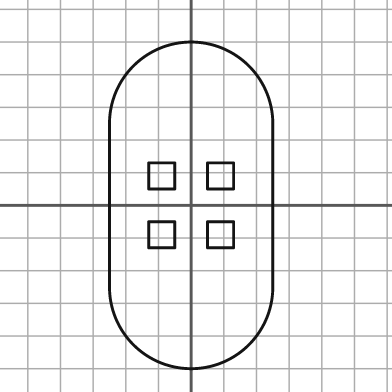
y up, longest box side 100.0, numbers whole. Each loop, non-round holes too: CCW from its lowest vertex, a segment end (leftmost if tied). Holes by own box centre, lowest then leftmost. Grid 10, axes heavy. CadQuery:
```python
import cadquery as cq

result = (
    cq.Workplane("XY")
    .moveTo(-25.0, -25.0)
    .threePointArc((0.0, -50.0), (25.0, -25.0))
    .lineTo(25.0, 25.0)
    .threePointArc((0.0, 50.0), (-25.0, 25.0))
    .close()
    .moveTo(-13.0, -13.0)
    .lineTo(-5.0, -13.0)
    .lineTo(-5.0, -5.0)
    .lineTo(-13.0, -5.0)
    .close()
    .moveTo(5.0, -13.0)
    .lineTo(13.0, -13.0)
    .lineTo(13.0, -5.0)
    .lineTo(5.0, -5.0)
    .close()
    .moveTo(-13.0, 5.0)
    .lineTo(-5.0, 5.0)
    .lineTo(-5.0, 13.0)
    .lineTo(-13.0, 13.0)
    .close()
    .moveTo(5.0, 5.0)
    .lineTo(13.0, 5.0)
    .lineTo(13.0, 13.0)
    .lineTo(5.0, 13.0)
    .close()
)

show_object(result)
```